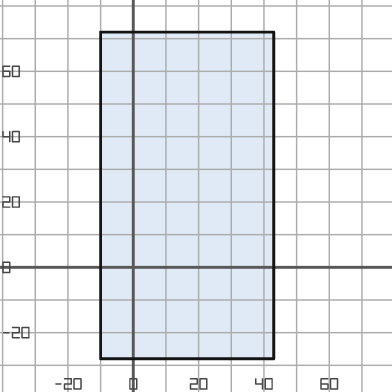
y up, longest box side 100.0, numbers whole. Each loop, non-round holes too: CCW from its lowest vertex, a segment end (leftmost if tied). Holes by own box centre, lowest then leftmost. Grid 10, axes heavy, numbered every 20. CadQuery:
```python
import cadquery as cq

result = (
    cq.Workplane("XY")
    .moveTo(-10.0, -28.0)
    .lineTo(43.0, -28.0)
    .lineTo(43.0, 72.0)
    .lineTo(-10.0, 72.0)
    .close()
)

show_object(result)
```